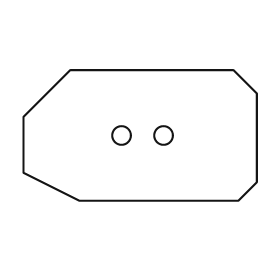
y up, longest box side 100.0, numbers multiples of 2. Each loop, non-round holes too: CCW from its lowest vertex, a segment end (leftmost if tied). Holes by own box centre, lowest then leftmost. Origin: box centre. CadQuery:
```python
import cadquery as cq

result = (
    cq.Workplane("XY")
    .moveTo(-26.0, -28.0)
    .lineTo(42.0, -28.0)
    .lineTo(50.0, -20.0)
    .lineTo(50.0, 18.0)
    .lineTo(40.0, 28.0)
    .lineTo(-30.0, 28.0)
    .lineTo(-50.0, 8.0)
    .lineTo(-50.0, -16.0)
    .close()
    .moveTo(-8.0, 0.0)
    .circle(4.0)
    .moveTo(10.0, 0.0)
    .circle(4.0)
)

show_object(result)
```